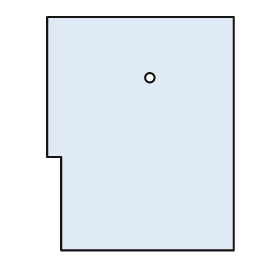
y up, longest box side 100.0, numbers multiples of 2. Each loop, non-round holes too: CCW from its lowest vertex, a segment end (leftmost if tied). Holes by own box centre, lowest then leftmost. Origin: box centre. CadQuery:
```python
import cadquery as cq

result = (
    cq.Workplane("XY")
    .moveTo(-34.0, -50.0)
    .lineTo(40.0, -50.0)
    .lineTo(40.0, 50.0)
    .lineTo(-40.0, 50.0)
    .lineTo(-40.0, -10.0)
    .lineTo(-34.0, -10.0)
    .close()
    .moveTo(4.0, 24.0)
    .circle(2.0)
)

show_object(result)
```